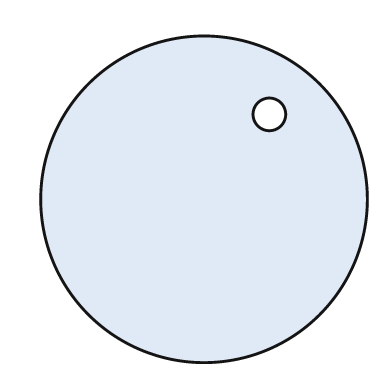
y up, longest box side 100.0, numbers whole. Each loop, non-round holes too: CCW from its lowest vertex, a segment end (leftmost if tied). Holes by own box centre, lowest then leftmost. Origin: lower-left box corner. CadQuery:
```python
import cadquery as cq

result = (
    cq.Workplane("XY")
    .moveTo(50.0, 50.0)
    .circle(50.0)
    .moveTo(70.0, 76.0)
    .circle(5.0)
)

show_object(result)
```